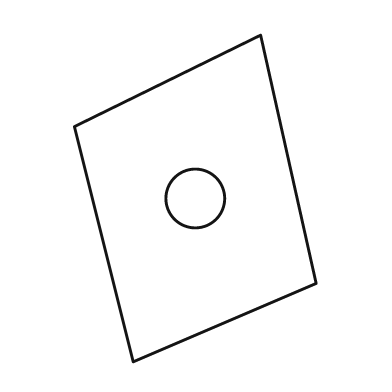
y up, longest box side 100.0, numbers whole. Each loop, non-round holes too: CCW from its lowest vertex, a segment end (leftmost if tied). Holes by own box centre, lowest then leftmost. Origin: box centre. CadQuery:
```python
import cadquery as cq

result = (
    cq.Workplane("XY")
    .moveTo(-19.0, -50.0)
    .lineTo(37.0, -26.0)
    .lineTo(20.0, 50.0)
    .lineTo(-37.0, 22.0)
    .close()
    .moveTo(0.0, 0.0)
    .circle(9.0)
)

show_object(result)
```